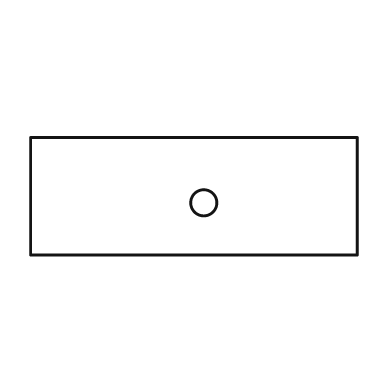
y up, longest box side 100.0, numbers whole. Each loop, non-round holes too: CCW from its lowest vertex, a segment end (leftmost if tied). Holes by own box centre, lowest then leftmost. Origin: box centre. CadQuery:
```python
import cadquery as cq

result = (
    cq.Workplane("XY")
    .moveTo(-50.0, -18.0)
    .lineTo(50.0, -18.0)
    .lineTo(50.0, 18.0)
    .lineTo(-50.0, 18.0)
    .close()
    .moveTo(3.0, -2.0)
    .circle(4.0)
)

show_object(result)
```